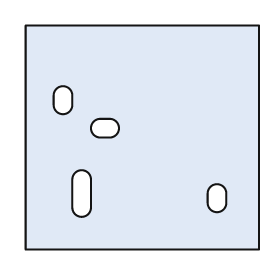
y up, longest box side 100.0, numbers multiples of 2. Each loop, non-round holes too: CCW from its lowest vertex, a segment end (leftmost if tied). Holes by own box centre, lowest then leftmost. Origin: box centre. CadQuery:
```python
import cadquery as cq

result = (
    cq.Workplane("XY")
    .moveTo(-50.0, -48.0)
    .lineTo(50.0, -48.0)
    .lineTo(50.0, 48.0)
    .lineTo(-50.0, 48.0)
    .close()
    .moveTo(28.0, -28.0)
    .threePointArc((32.0, -32.0), (36.0, -28.0))
    .lineTo(36.0, -24.0)
    .threePointArc((32.0, -20.0), (28.0, -24.0))
    .close()
    .moveTo(-30.0, -30.0)
    .threePointArc((-26.0, -34.0), (-22.0, -30.0))
    .lineTo(-22.0, -18.0)
    .threePointArc((-26.0, -14.0), (-30.0, -18.0))
    .close()
    .moveTo(-18.0, 0.0)
    .lineTo(-14.0, 0.0)
    .threePointArc((-10.0, 4.0), (-14.0, 8.0))
    .lineTo(-18.0, 8.0)
    .threePointArc((-22.0, 4.0), (-18.0, 0.0))
    .close()
    .moveTo(-38.0, 14.0)
    .threePointArc((-34.0, 10.0), (-30.0, 14.0))
    .lineTo(-30.0, 18.0)
    .threePointArc((-34.0, 22.0), (-38.0, 18.0))
    .close()
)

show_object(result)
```